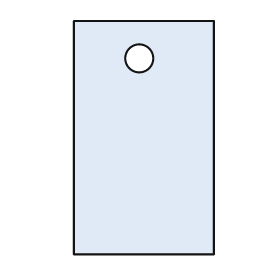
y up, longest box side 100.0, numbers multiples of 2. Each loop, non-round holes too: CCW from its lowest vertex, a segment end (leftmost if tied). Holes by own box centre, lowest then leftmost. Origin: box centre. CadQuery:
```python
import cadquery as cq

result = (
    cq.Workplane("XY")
    .moveTo(-30.0, -50.0)
    .lineTo(30.0, -50.0)
    .lineTo(30.0, 50.0)
    .lineTo(-30.0, 50.0)
    .close()
    .moveTo(-2.0, 34.0)
    .circle(6.0)
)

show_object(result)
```